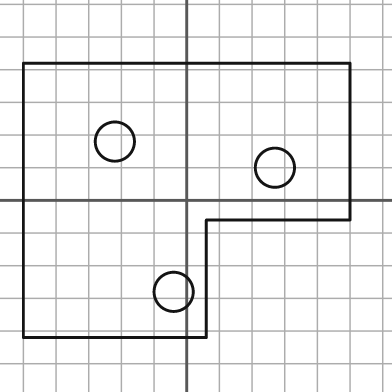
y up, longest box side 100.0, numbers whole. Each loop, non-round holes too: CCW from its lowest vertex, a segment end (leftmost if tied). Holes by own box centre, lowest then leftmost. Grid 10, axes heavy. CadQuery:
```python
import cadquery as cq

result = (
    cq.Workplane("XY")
    .moveTo(-50.0, -42.0)
    .lineTo(6.0, -42.0)
    .lineTo(6.0, -6.0)
    .lineTo(50.0, -6.0)
    .lineTo(50.0, 42.0)
    .lineTo(-50.0, 42.0)
    .close()
    .moveTo(-4.0, -28.0)
    .circle(6.0)
    .moveTo(27.0, 10.0)
    .circle(6.0)
    .moveTo(-22.0, 18.0)
    .circle(6.0)
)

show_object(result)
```